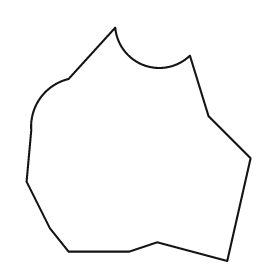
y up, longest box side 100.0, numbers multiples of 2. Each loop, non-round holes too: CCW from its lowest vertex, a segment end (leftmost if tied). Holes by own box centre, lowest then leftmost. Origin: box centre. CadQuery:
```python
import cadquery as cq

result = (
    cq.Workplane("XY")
    .moveTo(38.0, -50.0)
    .lineTo(48.0, -6.0)
    .lineTo(30.0, 12.0)
    .lineTo(22.0, 38.0)
    .threePointArc((2.0, 34.0), (-10.0, 50.0))
    .lineTo(-30.0, 28.0)
    .threePointArc((-42.0, 20.0), (-46.0, 6.0))
    .lineTo(-48.0, -16.0)
    .lineTo(-38.0, -36.0)
    .lineTo(-30.0, -46.0)
    .lineTo(-4.0, -46.0)
    .lineTo(8.0, -42.0)
    .close()
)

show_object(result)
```